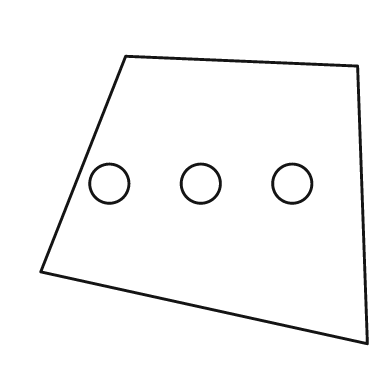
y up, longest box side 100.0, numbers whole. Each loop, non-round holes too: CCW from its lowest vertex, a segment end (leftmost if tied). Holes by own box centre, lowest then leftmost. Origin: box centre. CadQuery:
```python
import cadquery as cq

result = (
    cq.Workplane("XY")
    .moveTo(50.0, -44.0)
    .lineTo(47.0, 41.0)
    .lineTo(-24.0, 44.0)
    .lineTo(-50.0, -22.0)
    .close()
    .moveTo(-29.0, 5.0)
    .circle(6.0)
    .moveTo(-1.0, 5.0)
    .circle(6.0)
    .moveTo(27.0, 5.0)
    .circle(6.0)
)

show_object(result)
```